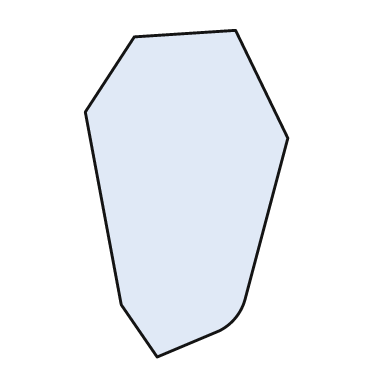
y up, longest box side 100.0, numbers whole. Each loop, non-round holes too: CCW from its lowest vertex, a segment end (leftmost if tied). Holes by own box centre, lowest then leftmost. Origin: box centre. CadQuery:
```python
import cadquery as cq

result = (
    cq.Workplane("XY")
    .moveTo(-9.0, -50.0)
    .lineTo(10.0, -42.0)
    .threePointArc((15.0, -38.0), (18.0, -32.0))
    .lineTo(31.0, 17.0)
    .lineTo(15.0, 50.0)
    .lineTo(-16.0, 48.0)
    .lineTo(-31.0, 25.0)
    .lineTo(-20.0, -34.0)
    .close()
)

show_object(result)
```